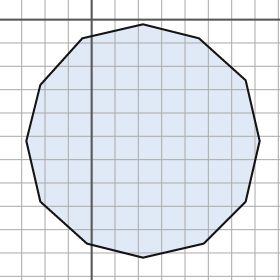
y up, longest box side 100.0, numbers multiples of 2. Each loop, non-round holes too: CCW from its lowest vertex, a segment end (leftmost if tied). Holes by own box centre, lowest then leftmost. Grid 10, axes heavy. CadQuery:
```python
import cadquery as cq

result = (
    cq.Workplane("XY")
    .moveTo(22.0, -102.0)
    .lineTo(48.0, -96.0)
    .lineTo(66.0, -78.0)
    .lineTo(72.0, -52.0)
    .lineTo(66.0, -26.0)
    .lineTo(46.0, -8.0)
    .lineTo(22.0, -2.0)
    .lineTo(-4.0, -8.0)
    .lineTo(-22.0, -28.0)
    .lineTo(-28.0, -52.0)
    .lineTo(-22.0, -78.0)
    .lineTo(-2.0, -96.0)
    .close()
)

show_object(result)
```